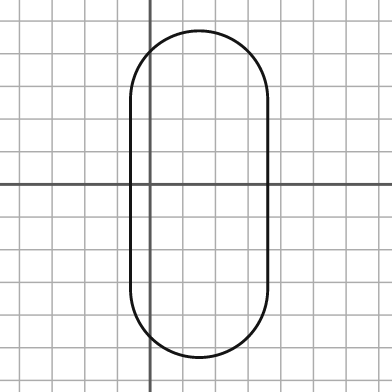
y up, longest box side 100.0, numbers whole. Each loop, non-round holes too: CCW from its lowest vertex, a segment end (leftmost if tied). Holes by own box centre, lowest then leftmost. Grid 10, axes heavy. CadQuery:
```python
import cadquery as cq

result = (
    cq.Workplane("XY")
    .moveTo(-6.0, -32.0)
    .threePointArc((15.0, -53.0), (36.0, -32.0))
    .lineTo(36.0, 26.0)
    .threePointArc((15.0, 47.0), (-6.0, 26.0))
    .close()
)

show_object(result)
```